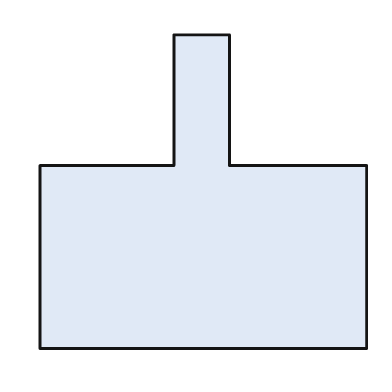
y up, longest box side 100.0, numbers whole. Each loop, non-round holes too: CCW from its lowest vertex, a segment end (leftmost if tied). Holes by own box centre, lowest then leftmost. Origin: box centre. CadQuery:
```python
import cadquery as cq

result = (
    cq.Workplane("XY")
    .moveTo(-50.0, -48.0)
    .lineTo(50.0, -48.0)
    .lineTo(50.0, 8.0)
    .lineTo(8.0, 8.0)
    .lineTo(8.0, 48.0)
    .lineTo(-9.0, 48.0)
    .lineTo(-9.0, 8.0)
    .lineTo(-50.0, 8.0)
    .close()
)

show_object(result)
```